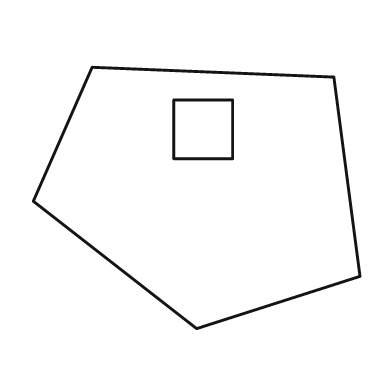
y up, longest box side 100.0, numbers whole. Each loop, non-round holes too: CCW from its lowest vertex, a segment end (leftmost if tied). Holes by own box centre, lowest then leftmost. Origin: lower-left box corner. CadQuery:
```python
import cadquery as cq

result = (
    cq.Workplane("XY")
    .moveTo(50.0, 0.0)
    .lineTo(100.0, 16.0)
    .lineTo(92.0, 77.0)
    .lineTo(18.0, 80.0)
    .lineTo(0.0, 39.0)
    .close()
    .moveTo(43.0, 52.0)
    .lineTo(61.0, 52.0)
    .lineTo(61.0, 70.0)
    .lineTo(43.0, 70.0)
    .close()
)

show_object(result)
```